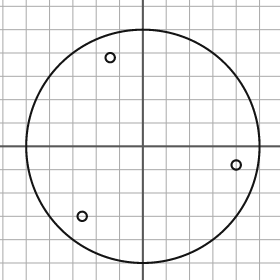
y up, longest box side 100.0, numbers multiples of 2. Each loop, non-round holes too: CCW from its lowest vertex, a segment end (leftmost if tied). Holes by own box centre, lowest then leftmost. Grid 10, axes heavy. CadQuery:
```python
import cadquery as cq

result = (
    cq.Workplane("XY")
    .moveTo(0.0, 0.0)
    .circle(50.0)
    .moveTo(-26.0, -30.0)
    .circle(2.0)
    .moveTo(40.0, -8.0)
    .circle(2.0)
    .moveTo(-14.0, 38.0)
    .circle(2.0)
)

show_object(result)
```